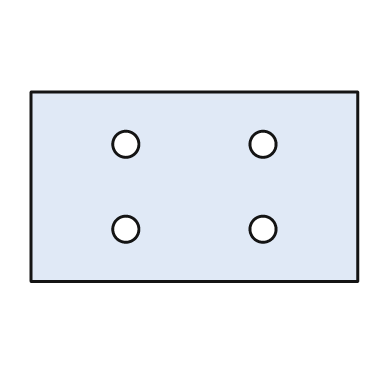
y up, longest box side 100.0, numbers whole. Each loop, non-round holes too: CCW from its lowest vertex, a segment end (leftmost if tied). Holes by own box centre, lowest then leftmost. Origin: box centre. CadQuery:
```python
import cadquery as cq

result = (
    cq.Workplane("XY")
    .moveTo(-50.0, -29.0)
    .lineTo(50.0, -29.0)
    .lineTo(50.0, 29.0)
    .lineTo(-50.0, 29.0)
    .close()
    .moveTo(-21.0, -13.0)
    .circle(4.0)
    .moveTo(21.0, -13.0)
    .circle(4.0)
    .moveTo(-21.0, 13.0)
    .circle(4.0)
    .moveTo(21.0, 13.0)
    .circle(4.0)
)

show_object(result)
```